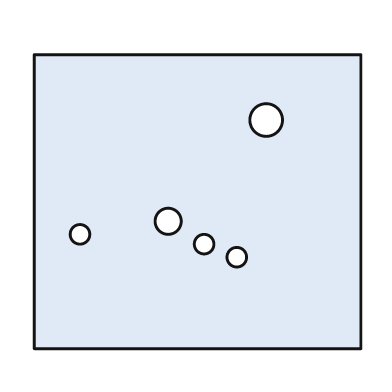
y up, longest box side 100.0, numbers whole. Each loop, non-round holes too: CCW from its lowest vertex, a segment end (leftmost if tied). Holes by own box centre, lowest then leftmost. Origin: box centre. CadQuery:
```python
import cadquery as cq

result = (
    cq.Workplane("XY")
    .moveTo(-50.0, -45.0)
    .lineTo(50.0, -45.0)
    .lineTo(50.0, 45.0)
    .lineTo(-50.0, 45.0)
    .close()
    .moveTo(12.0, -17.0)
    .circle(3.0)
    .moveTo(2.0, -13.0)
    .circle(3.0)
    .moveTo(-36.0, -10.0)
    .circle(3.0)
    .moveTo(-9.0, -6.0)
    .circle(4.0)
    .moveTo(21.0, 25.0)
    .circle(5.0)
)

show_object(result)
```